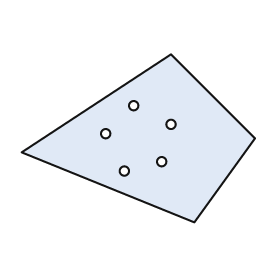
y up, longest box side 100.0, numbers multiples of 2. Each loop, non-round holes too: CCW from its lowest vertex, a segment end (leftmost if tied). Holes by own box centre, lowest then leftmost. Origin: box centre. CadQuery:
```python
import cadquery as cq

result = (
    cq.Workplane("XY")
    .moveTo(24.0, -36.0)
    .lineTo(50.0, 0.0)
    .lineTo(14.0, 36.0)
    .lineTo(-50.0, -6.0)
    .close()
    .moveTo(-6.0, -14.0)
    .circle(2.0)
    .moveTo(10.0, -10.0)
    .circle(2.0)
    .moveTo(-14.0, 2.0)
    .circle(2.0)
    .moveTo(14.0, 6.0)
    .circle(2.0)
    .moveTo(-2.0, 14.0)
    .circle(2.0)
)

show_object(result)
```